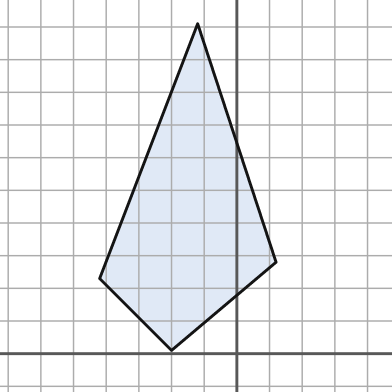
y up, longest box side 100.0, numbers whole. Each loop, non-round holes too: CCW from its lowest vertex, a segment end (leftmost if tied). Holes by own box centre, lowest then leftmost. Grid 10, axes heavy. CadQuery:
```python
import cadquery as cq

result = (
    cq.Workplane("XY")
    .moveTo(-20.0, 1.0)
    .lineTo(12.0, 28.0)
    .lineTo(-12.0, 101.0)
    .lineTo(-42.0, 23.0)
    .close()
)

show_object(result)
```